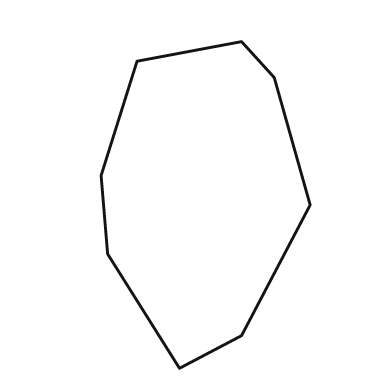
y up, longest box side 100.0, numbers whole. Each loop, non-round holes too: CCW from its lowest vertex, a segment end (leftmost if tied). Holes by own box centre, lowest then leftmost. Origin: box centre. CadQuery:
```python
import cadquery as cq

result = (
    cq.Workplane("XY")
    .moveTo(-8.0, -50.0)
    .lineTo(11.0, -40.0)
    .lineTo(32.0, 0.0)
    .lineTo(21.0, 39.0)
    .lineTo(11.0, 50.0)
    .lineTo(-21.0, 44.0)
    .lineTo(-32.0, 9.0)
    .lineTo(-30.0, -15.0)
    .close()
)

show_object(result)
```